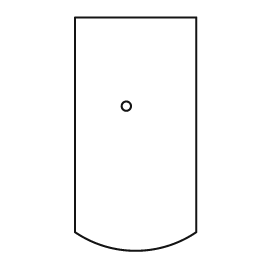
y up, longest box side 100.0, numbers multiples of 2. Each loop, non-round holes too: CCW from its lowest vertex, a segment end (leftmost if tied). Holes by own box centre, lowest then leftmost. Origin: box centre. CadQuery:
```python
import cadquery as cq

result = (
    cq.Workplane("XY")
    .moveTo(-26.0, -42.0)
    .threePointArc((0.0, -50.0), (26.0, -42.0))
    .lineTo(26.0, 50.0)
    .lineTo(-26.0, 50.0)
    .close()
    .moveTo(-4.0, 12.0)
    .circle(2.0)
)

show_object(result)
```